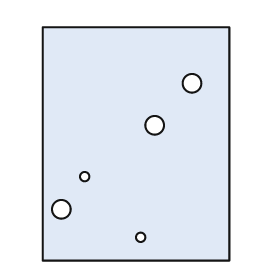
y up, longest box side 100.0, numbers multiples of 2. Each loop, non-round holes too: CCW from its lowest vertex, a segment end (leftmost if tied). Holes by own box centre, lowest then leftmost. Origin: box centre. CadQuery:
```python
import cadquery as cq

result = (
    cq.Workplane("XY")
    .moveTo(-40.0, -50.0)
    .lineTo(40.0, -50.0)
    .lineTo(40.0, 50.0)
    .lineTo(-40.0, 50.0)
    .close()
    .moveTo(2.0, -40.0)
    .circle(2.0)
    .moveTo(-32.0, -28.0)
    .circle(4.0)
    .moveTo(-22.0, -14.0)
    .circle(2.0)
    .moveTo(8.0, 8.0)
    .circle(4.0)
    .moveTo(24.0, 26.0)
    .circle(4.0)
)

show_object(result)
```